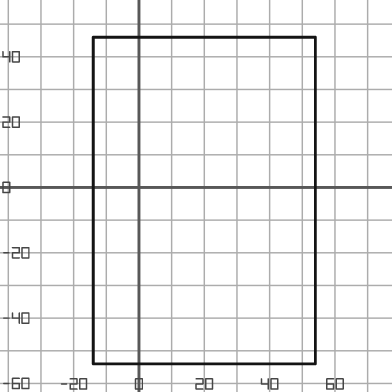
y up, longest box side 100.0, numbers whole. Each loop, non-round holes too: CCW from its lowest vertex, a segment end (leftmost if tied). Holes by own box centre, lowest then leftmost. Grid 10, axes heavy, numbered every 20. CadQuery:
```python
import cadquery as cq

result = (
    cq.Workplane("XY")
    .moveTo(-14.0, -54.0)
    .lineTo(54.0, -54.0)
    .lineTo(54.0, 46.0)
    .lineTo(-14.0, 46.0)
    .close()
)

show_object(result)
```